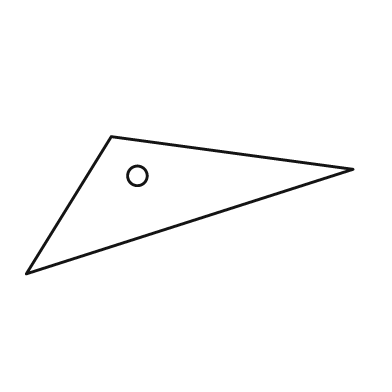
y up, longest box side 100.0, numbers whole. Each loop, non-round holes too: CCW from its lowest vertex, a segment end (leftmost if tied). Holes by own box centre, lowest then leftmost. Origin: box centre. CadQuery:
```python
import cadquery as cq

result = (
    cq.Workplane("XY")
    .moveTo(-50.0, -21.0)
    .lineTo(50.0, 11.0)
    .lineTo(-24.0, 21.0)
    .close()
    .moveTo(-16.0, 9.0)
    .circle(3.0)
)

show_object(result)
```